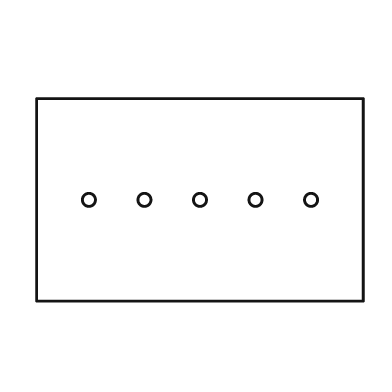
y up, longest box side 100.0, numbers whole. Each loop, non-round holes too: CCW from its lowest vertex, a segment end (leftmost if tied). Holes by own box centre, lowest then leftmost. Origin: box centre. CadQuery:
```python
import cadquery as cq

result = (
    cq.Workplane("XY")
    .moveTo(-50.0, -31.0)
    .lineTo(50.0, -31.0)
    .lineTo(50.0, 31.0)
    .lineTo(-50.0, 31.0)
    .close()
    .moveTo(-34.0, 0.0)
    .circle(2.0)
    .moveTo(-17.0, 0.0)
    .circle(2.0)
    .moveTo(0.0, 0.0)
    .circle(2.0)
    .moveTo(17.0, 0.0)
    .circle(2.0)
    .moveTo(34.0, 0.0)
    .circle(2.0)
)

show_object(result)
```